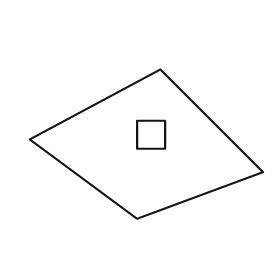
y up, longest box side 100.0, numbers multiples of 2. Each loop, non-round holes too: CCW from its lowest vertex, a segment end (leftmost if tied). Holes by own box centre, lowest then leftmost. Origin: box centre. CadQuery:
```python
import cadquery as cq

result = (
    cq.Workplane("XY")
    .moveTo(-4.0, -32.0)
    .lineTo(50.0, -12.0)
    .lineTo(6.0, 32.0)
    .lineTo(-50.0, 2.0)
    .close()
    .moveTo(-4.0, -2.0)
    .lineTo(8.0, -2.0)
    .lineTo(8.0, 10.0)
    .lineTo(-4.0, 10.0)
    .close()
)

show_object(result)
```